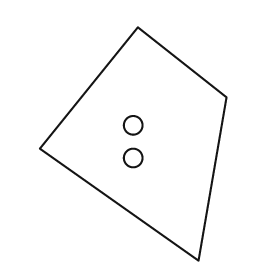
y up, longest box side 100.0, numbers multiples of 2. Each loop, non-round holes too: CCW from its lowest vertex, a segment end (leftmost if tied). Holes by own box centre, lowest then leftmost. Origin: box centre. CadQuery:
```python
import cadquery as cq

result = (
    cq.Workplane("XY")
    .moveTo(28.0, -50.0)
    .lineTo(40.0, 20.0)
    .lineTo(2.0, 50.0)
    .lineTo(-40.0, -2.0)
    .close()
    .moveTo(0.0, -6.0)
    .circle(4.0)
    .moveTo(0.0, 8.0)
    .circle(4.0)
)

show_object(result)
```